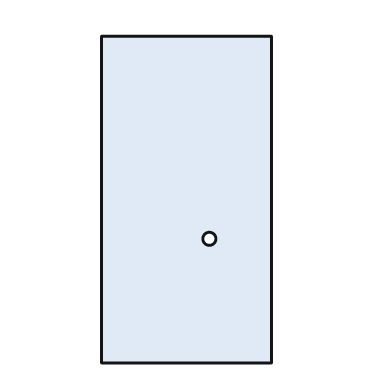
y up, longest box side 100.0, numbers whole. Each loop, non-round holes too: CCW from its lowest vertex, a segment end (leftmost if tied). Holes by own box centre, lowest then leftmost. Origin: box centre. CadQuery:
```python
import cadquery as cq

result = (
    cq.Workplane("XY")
    .moveTo(-26.0, -50.0)
    .lineTo(26.0, -50.0)
    .lineTo(26.0, 50.0)
    .lineTo(-26.0, 50.0)
    .close()
    .moveTo(7.0, -12.0)
    .circle(2.0)
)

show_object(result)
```